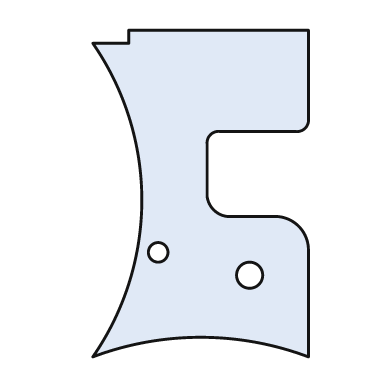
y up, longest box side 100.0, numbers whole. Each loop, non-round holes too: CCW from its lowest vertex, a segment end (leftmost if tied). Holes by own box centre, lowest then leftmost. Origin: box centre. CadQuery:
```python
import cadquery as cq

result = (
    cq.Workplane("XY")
    .moveTo(-33.0, -50.0)
    .threePointArc((0.0, -44.0), (33.0, -50.0))
    .lineTo(33.0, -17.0)
    .threePointArc((30.0, -10.0), (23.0, -7.0))
    .lineTo(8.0, -7.0)
    .threePointArc((4.0, -5.0), (2.0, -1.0))
    .lineTo(2.0, 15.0)
    .threePointArc((3.0, 18.0), (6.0, 19.0))
    .lineTo(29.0, 19.0)
    .threePointArc((32.0, 20.0), (33.0, 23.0))
    .lineTo(33.0, 50.0)
    .lineTo(-22.0, 50.0)
    .lineTo(-22.0, 46.0)
    .lineTo(-33.0, 46.0)
    .threePointArc((-18.0, -2.0), (-33.0, -50.0))
    .close()
    .moveTo(15.0, -25.0)
    .circle(4.0)
    .moveTo(-13.0, -18.0)
    .circle(3.0)
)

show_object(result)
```